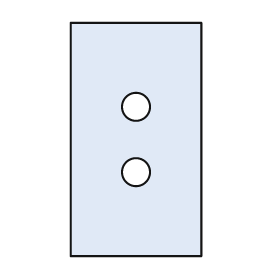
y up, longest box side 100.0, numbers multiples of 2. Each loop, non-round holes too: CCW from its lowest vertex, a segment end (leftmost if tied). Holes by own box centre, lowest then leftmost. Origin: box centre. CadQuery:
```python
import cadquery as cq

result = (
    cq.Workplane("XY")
    .moveTo(-28.0, -50.0)
    .lineTo(28.0, -50.0)
    .lineTo(28.0, 50.0)
    .lineTo(-28.0, 50.0)
    .close()
    .moveTo(0.0, -14.0)
    .circle(6.0)
    .moveTo(0.0, 14.0)
    .circle(6.0)
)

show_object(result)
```